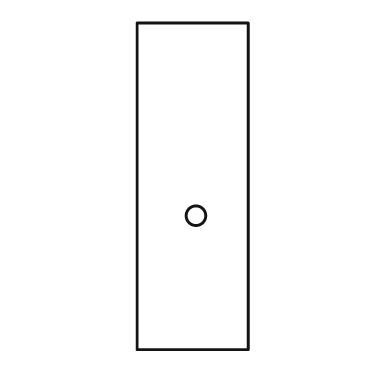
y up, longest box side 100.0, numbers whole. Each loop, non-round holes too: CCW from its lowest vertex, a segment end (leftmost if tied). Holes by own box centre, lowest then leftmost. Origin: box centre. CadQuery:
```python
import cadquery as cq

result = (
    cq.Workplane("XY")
    .moveTo(-17.0, -50.0)
    .lineTo(17.0, -50.0)
    .lineTo(17.0, 50.0)
    .lineTo(-17.0, 50.0)
    .close()
    .moveTo(1.0, -9.0)
    .circle(3.0)
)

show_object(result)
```